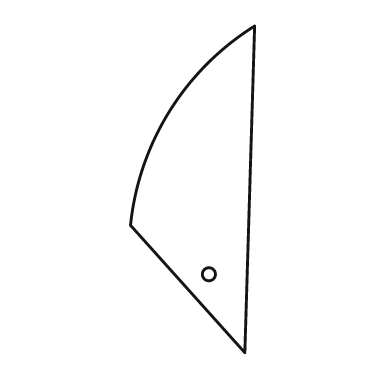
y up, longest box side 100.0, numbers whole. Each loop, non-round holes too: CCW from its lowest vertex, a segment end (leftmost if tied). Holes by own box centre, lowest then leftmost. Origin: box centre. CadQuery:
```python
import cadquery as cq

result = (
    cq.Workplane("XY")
    .moveTo(16.0, -50.0)
    .lineTo(19.0, 50.0)
    .threePointArc((-7.0, 24.0), (-19.0, -11.0))
    .close()
    .moveTo(5.0, -26.0)
    .circle(2.0)
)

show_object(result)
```